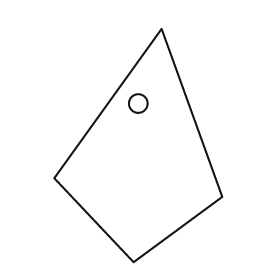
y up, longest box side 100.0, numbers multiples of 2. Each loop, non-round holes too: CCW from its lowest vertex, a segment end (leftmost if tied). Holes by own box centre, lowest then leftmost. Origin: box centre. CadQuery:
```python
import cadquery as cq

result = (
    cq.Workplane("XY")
    .moveTo(-2.0, -50.0)
    .lineTo(36.0, -22.0)
    .lineTo(10.0, 50.0)
    .lineTo(-36.0, -14.0)
    .close()
    .moveTo(0.0, 18.0)
    .circle(4.0)
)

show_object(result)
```